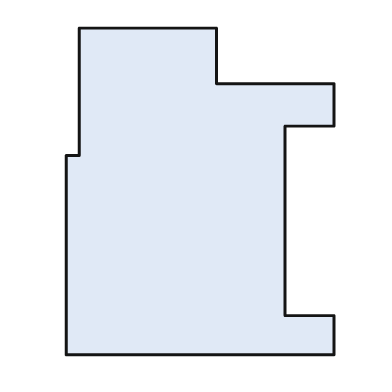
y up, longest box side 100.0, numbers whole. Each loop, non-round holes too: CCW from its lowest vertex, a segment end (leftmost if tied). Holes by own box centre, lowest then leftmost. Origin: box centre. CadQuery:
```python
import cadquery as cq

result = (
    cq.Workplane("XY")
    .moveTo(-41.0, -50.0)
    .lineTo(41.0, -50.0)
    .lineTo(41.0, -38.0)
    .lineTo(26.0, -38.0)
    .lineTo(26.0, 20.0)
    .lineTo(41.0, 20.0)
    .lineTo(41.0, 33.0)
    .lineTo(5.0, 33.0)
    .lineTo(5.0, 50.0)
    .lineTo(-37.0, 50.0)
    .lineTo(-37.0, 11.0)
    .lineTo(-41.0, 11.0)
    .close()
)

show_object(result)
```